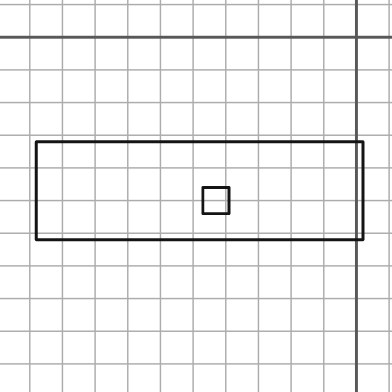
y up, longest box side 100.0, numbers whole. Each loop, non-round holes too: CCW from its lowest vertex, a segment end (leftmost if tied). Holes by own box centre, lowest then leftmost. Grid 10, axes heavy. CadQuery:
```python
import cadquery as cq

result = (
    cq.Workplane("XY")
    .moveTo(-98.0, -62.0)
    .lineTo(2.0, -62.0)
    .lineTo(2.0, -32.0)
    .lineTo(-98.0, -32.0)
    .close()
    .moveTo(-47.0, -54.0)
    .lineTo(-39.0, -54.0)
    .lineTo(-39.0, -46.0)
    .lineTo(-47.0, -46.0)
    .close()
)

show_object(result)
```